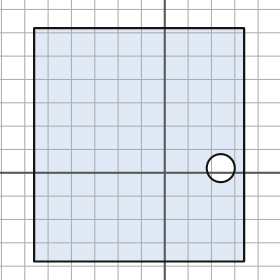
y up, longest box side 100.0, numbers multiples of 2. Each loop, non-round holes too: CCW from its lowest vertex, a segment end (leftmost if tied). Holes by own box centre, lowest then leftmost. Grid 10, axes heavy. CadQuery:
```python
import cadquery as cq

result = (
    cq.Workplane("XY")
    .moveTo(-56.0, -38.0)
    .lineTo(34.0, -38.0)
    .lineTo(34.0, 62.0)
    .lineTo(-56.0, 62.0)
    .close()
    .moveTo(24.0, 2.0)
    .circle(6.0)
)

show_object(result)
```